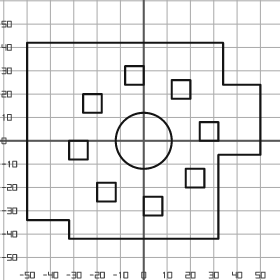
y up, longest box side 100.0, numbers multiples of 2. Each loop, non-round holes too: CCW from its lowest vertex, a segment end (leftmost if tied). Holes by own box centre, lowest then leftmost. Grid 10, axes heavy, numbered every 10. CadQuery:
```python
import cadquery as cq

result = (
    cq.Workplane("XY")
    .moveTo(-32.0, -42.0)
    .lineTo(32.0, -42.0)
    .lineTo(32.0, -6.0)
    .lineTo(50.0, -6.0)
    .lineTo(50.0, 24.0)
    .lineTo(34.0, 24.0)
    .lineTo(34.0, 42.0)
    .lineTo(-50.0, 42.0)
    .lineTo(-50.0, -34.0)
    .lineTo(-32.0, -34.0)
    .close()
    .moveTo(0.0, -32.0)
    .lineTo(8.0, -32.0)
    .lineTo(8.0, -24.0)
    .lineTo(0.0, -24.0)
    .close()
    .moveTo(-20.0, -26.0)
    .lineTo(-12.0, -26.0)
    .lineTo(-12.0, -18.0)
    .lineTo(-20.0, -18.0)
    .close()
    .moveTo(18.0, -20.0)
    .lineTo(26.0, -20.0)
    .lineTo(26.0, -12.0)
    .lineTo(18.0, -12.0)
    .close()
    .moveTo(-32.0, -8.0)
    .lineTo(-24.0, -8.0)
    .lineTo(-24.0, 0.0)
    .lineTo(-32.0, 0.0)
    .close()
    .moveTo(0.0, 0.0)
    .circle(12.0)
    .moveTo(24.0, 0.0)
    .lineTo(32.0, 0.0)
    .lineTo(32.0, 8.0)
    .lineTo(24.0, 8.0)
    .close()
    .moveTo(-26.0, 12.0)
    .lineTo(-18.0, 12.0)
    .lineTo(-18.0, 20.0)
    .lineTo(-26.0, 20.0)
    .close()
    .moveTo(12.0, 18.0)
    .lineTo(20.0, 18.0)
    .lineTo(20.0, 26.0)
    .lineTo(12.0, 26.0)
    .close()
    .moveTo(-8.0, 24.0)
    .lineTo(0.0, 24.0)
    .lineTo(0.0, 32.0)
    .lineTo(-8.0, 32.0)
    .close()
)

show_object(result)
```